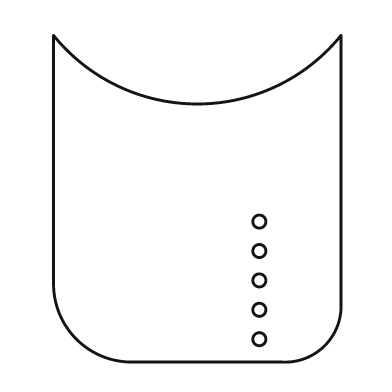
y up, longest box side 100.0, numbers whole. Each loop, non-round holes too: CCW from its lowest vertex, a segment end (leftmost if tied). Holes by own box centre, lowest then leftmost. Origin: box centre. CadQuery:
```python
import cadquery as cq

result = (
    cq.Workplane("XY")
    .moveTo(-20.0, -50.0)
    .lineTo(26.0, -50.0)
    .threePointArc((39.0, -45.0), (44.0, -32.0))
    .lineTo(44.0, 50.0)
    .threePointArc((0.0, 29.0), (-44.0, 50.0))
    .lineTo(-44.0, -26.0)
    .threePointArc((-37.0, -43.0), (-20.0, -50.0))
    .close()
    .moveTo(19.0, -43.0)
    .circle(2.0)
    .moveTo(19.0, -34.0)
    .circle(2.0)
    .moveTo(19.0, -25.0)
    .circle(2.0)
    .moveTo(19.0, -16.0)
    .circle(2.0)
    .moveTo(19.0, -7.0)
    .circle(2.0)
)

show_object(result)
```